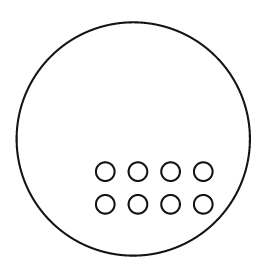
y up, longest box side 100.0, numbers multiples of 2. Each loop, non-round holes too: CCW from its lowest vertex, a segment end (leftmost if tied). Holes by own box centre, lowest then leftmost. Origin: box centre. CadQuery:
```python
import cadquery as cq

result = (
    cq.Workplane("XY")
    .moveTo(0.0, 0.0)
    .circle(50.0)
    .moveTo(-12.0, -28.0)
    .circle(4.0)
    .moveTo(2.0, -28.0)
    .circle(4.0)
    .moveTo(16.0, -28.0)
    .circle(4.0)
    .moveTo(30.0, -28.0)
    .circle(4.0)
    .moveTo(-12.0, -14.0)
    .circle(4.0)
    .moveTo(2.0, -14.0)
    .circle(4.0)
    .moveTo(16.0, -14.0)
    .circle(4.0)
    .moveTo(30.0, -14.0)
    .circle(4.0)
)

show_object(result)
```